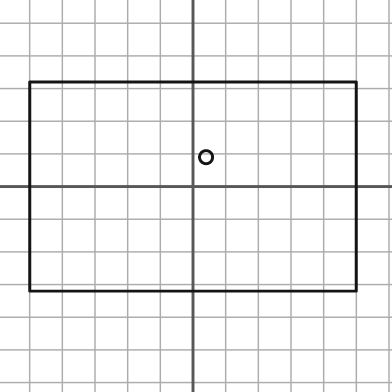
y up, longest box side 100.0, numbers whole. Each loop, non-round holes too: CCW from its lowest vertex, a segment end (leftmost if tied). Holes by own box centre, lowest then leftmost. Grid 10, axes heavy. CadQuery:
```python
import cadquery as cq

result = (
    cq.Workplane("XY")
    .moveTo(-50.0, -32.0)
    .lineTo(50.0, -32.0)
    .lineTo(50.0, 32.0)
    .lineTo(-50.0, 32.0)
    .close()
    .moveTo(4.0, 9.0)
    .circle(2.0)
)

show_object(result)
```